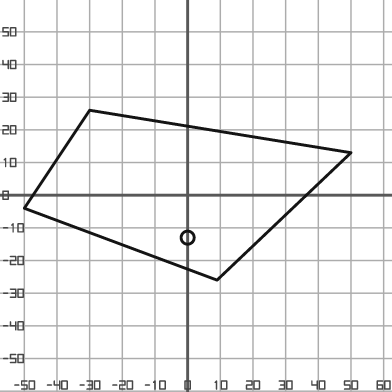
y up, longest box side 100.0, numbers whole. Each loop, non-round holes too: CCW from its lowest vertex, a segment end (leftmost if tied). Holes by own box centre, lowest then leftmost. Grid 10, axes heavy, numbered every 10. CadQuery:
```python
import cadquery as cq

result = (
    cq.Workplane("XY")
    .moveTo(9.0, -26.0)
    .lineTo(50.0, 13.0)
    .lineTo(-30.0, 26.0)
    .lineTo(-50.0, -4.0)
    .close()
    .moveTo(0.0, -13.0)
    .circle(2.0)
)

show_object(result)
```